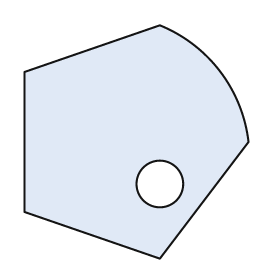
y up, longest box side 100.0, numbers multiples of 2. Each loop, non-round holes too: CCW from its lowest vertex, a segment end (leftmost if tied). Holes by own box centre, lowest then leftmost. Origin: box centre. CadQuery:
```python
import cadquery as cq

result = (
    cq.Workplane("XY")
    .moveTo(10.0, -50.0)
    .lineTo(48.0, 0.0)
    .threePointArc((36.0, 30.0), (10.0, 50.0))
    .lineTo(-48.0, 30.0)
    .lineTo(-48.0, -30.0)
    .close()
    .moveTo(10.0, -18.0)
    .circle(10.0)
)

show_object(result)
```